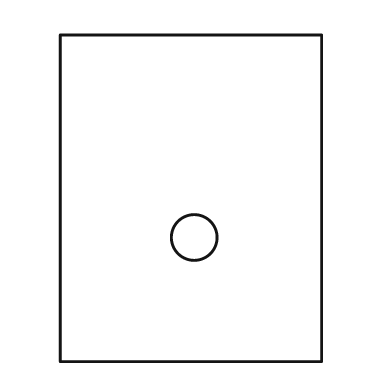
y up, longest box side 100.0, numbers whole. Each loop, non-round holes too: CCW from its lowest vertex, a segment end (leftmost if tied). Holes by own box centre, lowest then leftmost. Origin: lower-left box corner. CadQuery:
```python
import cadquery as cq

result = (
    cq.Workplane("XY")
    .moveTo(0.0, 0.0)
    .lineTo(80.0, 0.0)
    .lineTo(80.0, 100.0)
    .lineTo(0.0, 100.0)
    .close()
    .moveTo(41.0, 38.0)
    .circle(7.0)
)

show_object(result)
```